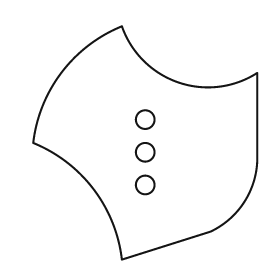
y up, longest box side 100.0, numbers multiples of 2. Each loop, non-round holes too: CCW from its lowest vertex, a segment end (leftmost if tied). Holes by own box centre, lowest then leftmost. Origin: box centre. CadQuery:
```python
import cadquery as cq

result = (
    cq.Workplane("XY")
    .moveTo(-10.0, -50.0)
    .lineTo(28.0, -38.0)
    .threePointArc((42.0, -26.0), (48.0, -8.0))
    .lineTo(48.0, 30.0)
    .threePointArc((14.0, 26.0), (-10.0, 50.0))
    .threePointArc((-36.0, 30.0), (-48.0, 0.0))
    .threePointArc((-22.0, -20.0), (-10.0, -50.0))
    .close()
    .moveTo(0.0, -18.0)
    .circle(4.0)
    .moveTo(0.0, -4.0)
    .circle(4.0)
    .moveTo(0.0, 10.0)
    .circle(4.0)
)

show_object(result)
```